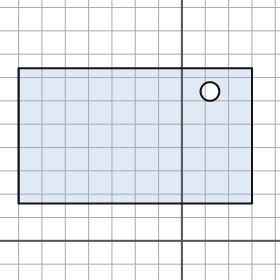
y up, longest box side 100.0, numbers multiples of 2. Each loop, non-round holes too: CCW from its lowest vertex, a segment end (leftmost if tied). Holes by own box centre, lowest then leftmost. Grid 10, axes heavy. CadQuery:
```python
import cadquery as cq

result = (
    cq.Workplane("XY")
    .moveTo(-70.0, 16.0)
    .lineTo(30.0, 16.0)
    .lineTo(30.0, 74.0)
    .lineTo(-70.0, 74.0)
    .close()
    .moveTo(12.0, 64.0)
    .circle(4.0)
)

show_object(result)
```